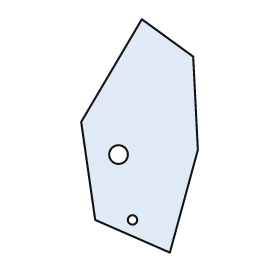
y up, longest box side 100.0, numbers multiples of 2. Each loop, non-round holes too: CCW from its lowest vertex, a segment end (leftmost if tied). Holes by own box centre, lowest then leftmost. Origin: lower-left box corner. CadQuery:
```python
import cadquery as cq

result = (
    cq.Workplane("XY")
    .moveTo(38.0, 0.0)
    .lineTo(50.0, 44.0)
    .lineTo(48.0, 84.0)
    .lineTo(26.0, 100.0)
    .lineTo(0.0, 56.0)
    .lineTo(6.0, 14.0)
    .close()
    .moveTo(22.0, 14.0)
    .circle(2.0)
    .moveTo(16.0, 42.0)
    .circle(4.0)
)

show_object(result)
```